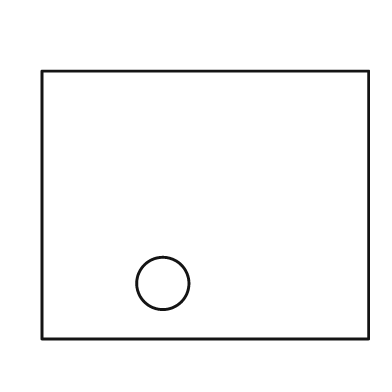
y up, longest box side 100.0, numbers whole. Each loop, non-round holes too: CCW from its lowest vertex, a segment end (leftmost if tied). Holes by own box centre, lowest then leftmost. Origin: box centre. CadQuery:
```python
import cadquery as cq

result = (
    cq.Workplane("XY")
    .moveTo(-50.0, -41.0)
    .lineTo(50.0, -41.0)
    .lineTo(50.0, 41.0)
    .lineTo(-50.0, 41.0)
    .close()
    .moveTo(-13.0, -24.0)
    .circle(8.0)
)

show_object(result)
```